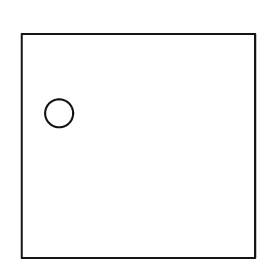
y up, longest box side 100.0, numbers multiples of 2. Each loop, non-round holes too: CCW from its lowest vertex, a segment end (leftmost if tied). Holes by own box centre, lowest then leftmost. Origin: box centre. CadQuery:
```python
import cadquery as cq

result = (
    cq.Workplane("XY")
    .moveTo(-50.0, -48.0)
    .lineTo(50.0, -48.0)
    .lineTo(50.0, 48.0)
    .lineTo(-50.0, 48.0)
    .close()
    .moveTo(-34.0, 14.0)
    .circle(6.0)
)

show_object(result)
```